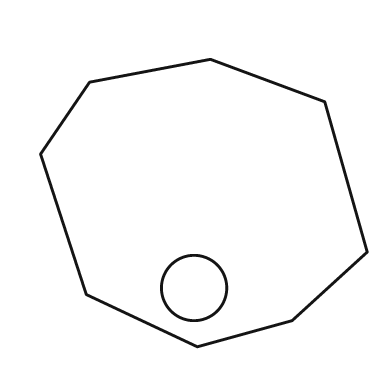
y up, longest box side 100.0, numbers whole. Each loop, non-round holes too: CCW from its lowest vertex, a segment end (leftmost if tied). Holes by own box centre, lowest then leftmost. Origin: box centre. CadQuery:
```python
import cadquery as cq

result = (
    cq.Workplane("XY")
    .moveTo(-2.0, -44.0)
    .lineTo(27.0, -36.0)
    .lineTo(50.0, -15.0)
    .lineTo(37.0, 31.0)
    .lineTo(2.0, 44.0)
    .lineTo(-35.0, 37.0)
    .lineTo(-50.0, 15.0)
    .lineTo(-36.0, -28.0)
    .close()
    .moveTo(-3.0, -26.0)
    .circle(10.0)
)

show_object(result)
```